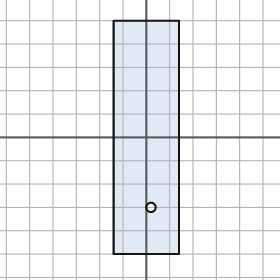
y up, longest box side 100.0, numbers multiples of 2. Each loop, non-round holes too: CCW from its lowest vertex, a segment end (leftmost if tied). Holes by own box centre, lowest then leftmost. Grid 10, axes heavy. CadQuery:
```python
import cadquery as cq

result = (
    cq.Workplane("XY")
    .moveTo(-14.0, -50.0)
    .lineTo(14.0, -50.0)
    .lineTo(14.0, 50.0)
    .lineTo(-14.0, 50.0)
    .close()
    .moveTo(2.0, -30.0)
    .circle(2.0)
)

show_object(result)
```